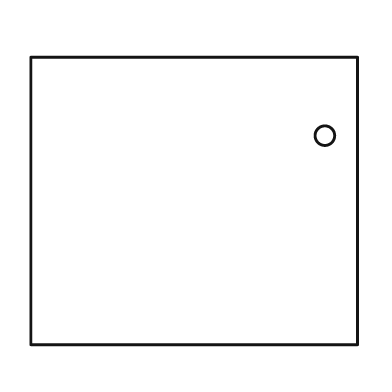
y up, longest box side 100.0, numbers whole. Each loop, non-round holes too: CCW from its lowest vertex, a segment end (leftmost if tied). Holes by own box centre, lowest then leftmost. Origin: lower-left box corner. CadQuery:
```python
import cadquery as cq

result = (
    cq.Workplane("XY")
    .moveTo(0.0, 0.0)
    .lineTo(100.0, 0.0)
    .lineTo(100.0, 88.0)
    .lineTo(0.0, 88.0)
    .close()
    .moveTo(90.0, 64.0)
    .circle(3.0)
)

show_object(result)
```